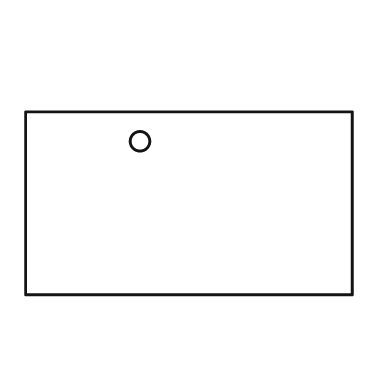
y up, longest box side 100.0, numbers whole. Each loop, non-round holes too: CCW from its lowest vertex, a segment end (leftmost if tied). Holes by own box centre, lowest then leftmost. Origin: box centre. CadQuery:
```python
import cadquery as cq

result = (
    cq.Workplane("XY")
    .moveTo(-50.0, -28.0)
    .lineTo(50.0, -28.0)
    .lineTo(50.0, 28.0)
    .lineTo(-50.0, 28.0)
    .close()
    .moveTo(-15.0, 19.0)
    .circle(3.0)
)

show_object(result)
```